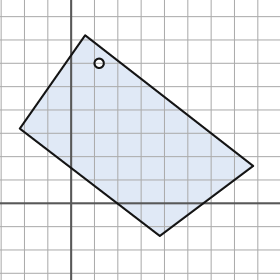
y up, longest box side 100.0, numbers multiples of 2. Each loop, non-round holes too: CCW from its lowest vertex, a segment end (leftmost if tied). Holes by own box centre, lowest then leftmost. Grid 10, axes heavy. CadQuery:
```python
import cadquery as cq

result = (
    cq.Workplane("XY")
    .moveTo(38.0, -14.0)
    .lineTo(78.0, 16.0)
    .lineTo(6.0, 72.0)
    .lineTo(-22.0, 32.0)
    .close()
    .moveTo(12.0, 60.0)
    .circle(2.0)
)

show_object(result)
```